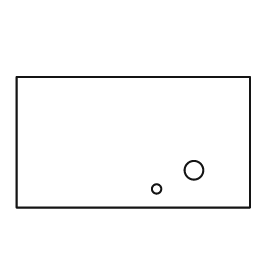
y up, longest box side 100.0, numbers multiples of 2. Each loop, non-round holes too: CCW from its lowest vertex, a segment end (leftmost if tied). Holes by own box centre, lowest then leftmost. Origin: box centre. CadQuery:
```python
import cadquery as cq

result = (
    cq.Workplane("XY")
    .moveTo(-50.0, -28.0)
    .lineTo(50.0, -28.0)
    .lineTo(50.0, 28.0)
    .lineTo(-50.0, 28.0)
    .close()
    .moveTo(10.0, -20.0)
    .circle(2.0)
    .moveTo(26.0, -12.0)
    .circle(4.0)
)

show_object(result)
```